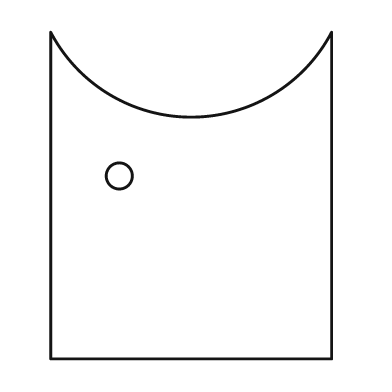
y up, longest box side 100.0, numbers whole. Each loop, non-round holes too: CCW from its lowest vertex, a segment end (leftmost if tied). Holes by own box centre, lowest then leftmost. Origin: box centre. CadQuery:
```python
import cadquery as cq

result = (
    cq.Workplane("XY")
    .moveTo(-43.0, -50.0)
    .lineTo(43.0, -50.0)
    .lineTo(43.0, 50.0)
    .threePointArc((0.0, 24.0), (-43.0, 50.0))
    .close()
    .moveTo(-22.0, 6.0)
    .circle(4.0)
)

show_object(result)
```